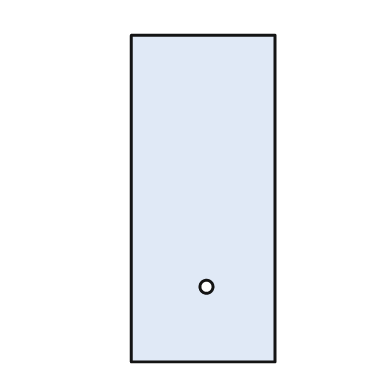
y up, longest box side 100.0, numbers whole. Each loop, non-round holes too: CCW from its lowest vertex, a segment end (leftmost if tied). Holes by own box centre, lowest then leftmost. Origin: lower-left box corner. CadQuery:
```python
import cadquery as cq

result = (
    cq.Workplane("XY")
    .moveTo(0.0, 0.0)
    .lineTo(44.0, 0.0)
    .lineTo(44.0, 100.0)
    .lineTo(0.0, 100.0)
    .close()
    .moveTo(23.0, 23.0)
    .circle(2.0)
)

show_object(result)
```